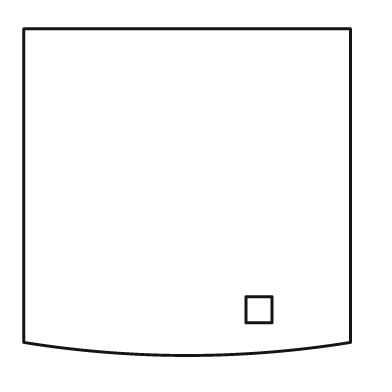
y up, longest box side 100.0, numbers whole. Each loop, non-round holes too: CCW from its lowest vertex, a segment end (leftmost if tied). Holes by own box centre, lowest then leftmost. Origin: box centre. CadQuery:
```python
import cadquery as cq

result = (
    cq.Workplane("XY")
    .moveTo(-50.0, -46.0)
    .threePointArc((0.0, -50.0), (50.0, -46.0))
    .lineTo(50.0, 50.0)
    .lineTo(-50.0, 50.0)
    .close()
    .moveTo(18.0, -40.0)
    .lineTo(26.0, -40.0)
    .lineTo(26.0, -32.0)
    .lineTo(18.0, -32.0)
    .close()
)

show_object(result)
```